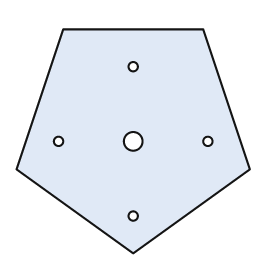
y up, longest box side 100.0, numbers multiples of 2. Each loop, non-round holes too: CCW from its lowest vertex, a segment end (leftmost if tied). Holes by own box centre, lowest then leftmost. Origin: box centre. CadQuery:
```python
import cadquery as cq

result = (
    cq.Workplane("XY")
    .moveTo(0.0, -48.0)
    .lineTo(50.0, -12.0)
    .lineTo(30.0, 48.0)
    .lineTo(-30.0, 48.0)
    .lineTo(-50.0, -12.0)
    .close()
    .moveTo(0.0, -32.0)
    .circle(2.0)
    .moveTo(-32.0, 0.0)
    .circle(2.0)
    .moveTo(0.0, 0.0)
    .circle(4.0)
    .moveTo(32.0, 0.0)
    .circle(2.0)
    .moveTo(0.0, 32.0)
    .circle(2.0)
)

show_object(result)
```